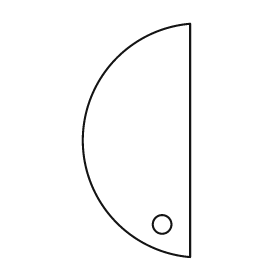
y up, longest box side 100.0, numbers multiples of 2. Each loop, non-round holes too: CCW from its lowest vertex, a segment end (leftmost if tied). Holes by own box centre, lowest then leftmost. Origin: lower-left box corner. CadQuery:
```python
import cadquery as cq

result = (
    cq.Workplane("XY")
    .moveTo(46.0, 0.0)
    .lineTo(46.0, 100.0)
    .threePointArc((0.0, 50.0), (46.0, 0.0))
    .close()
    .moveTo(34.0, 14.0)
    .circle(4.0)
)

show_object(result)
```